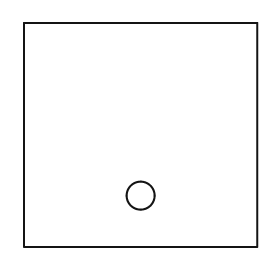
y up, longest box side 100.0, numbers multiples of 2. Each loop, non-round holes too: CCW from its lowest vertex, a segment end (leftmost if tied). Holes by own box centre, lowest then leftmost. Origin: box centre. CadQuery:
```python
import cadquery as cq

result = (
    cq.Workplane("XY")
    .moveTo(-50.0, -48.0)
    .lineTo(50.0, -48.0)
    .lineTo(50.0, 48.0)
    .lineTo(-50.0, 48.0)
    .close()
    .moveTo(0.0, -26.0)
    .circle(6.0)
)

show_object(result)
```